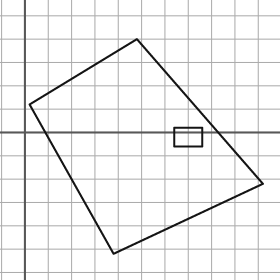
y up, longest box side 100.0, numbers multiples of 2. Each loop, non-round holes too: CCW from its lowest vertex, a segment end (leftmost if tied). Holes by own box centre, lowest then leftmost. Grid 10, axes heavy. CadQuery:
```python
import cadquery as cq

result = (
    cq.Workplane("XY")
    .moveTo(38.0, -52.0)
    .lineTo(102.0, -22.0)
    .lineTo(48.0, 40.0)
    .lineTo(2.0, 12.0)
    .close()
    .moveTo(64.0, -6.0)
    .lineTo(76.0, -6.0)
    .lineTo(76.0, 2.0)
    .lineTo(64.0, 2.0)
    .close()
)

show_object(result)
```